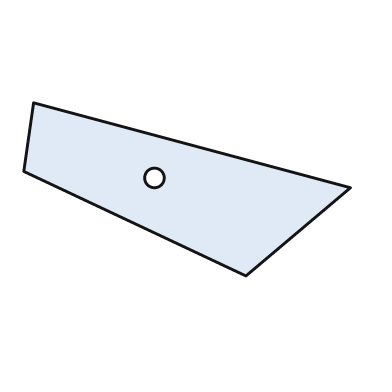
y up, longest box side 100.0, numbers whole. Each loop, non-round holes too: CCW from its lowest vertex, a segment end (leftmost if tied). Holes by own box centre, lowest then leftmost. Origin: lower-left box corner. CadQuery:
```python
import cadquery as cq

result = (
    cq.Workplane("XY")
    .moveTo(68.0, 0.0)
    .lineTo(100.0, 27.0)
    .lineTo(3.0, 53.0)
    .lineTo(0.0, 32.0)
    .close()
    .moveTo(40.0, 30.0)
    .circle(3.0)
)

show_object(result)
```